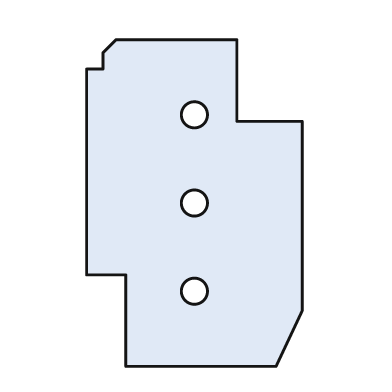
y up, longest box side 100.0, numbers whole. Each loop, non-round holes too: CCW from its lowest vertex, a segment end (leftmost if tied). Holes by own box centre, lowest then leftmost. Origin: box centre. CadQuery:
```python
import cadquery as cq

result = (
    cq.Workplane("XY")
    .moveTo(-21.0, -50.0)
    .lineTo(25.0, -50.0)
    .lineTo(33.0, -33.0)
    .lineTo(33.0, 25.0)
    .lineTo(13.0, 25.0)
    .lineTo(13.0, 50.0)
    .lineTo(-24.0, 50.0)
    .lineTo(-28.0, 46.0)
    .lineTo(-28.0, 41.0)
    .lineTo(-33.0, 41.0)
    .lineTo(-33.0, -22.0)
    .lineTo(-21.0, -22.0)
    .close()
    .moveTo(0.0, -27.0)
    .circle(4.0)
    .moveTo(0.0, 0.0)
    .circle(4.0)
    .moveTo(0.0, 27.0)
    .circle(4.0)
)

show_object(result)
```